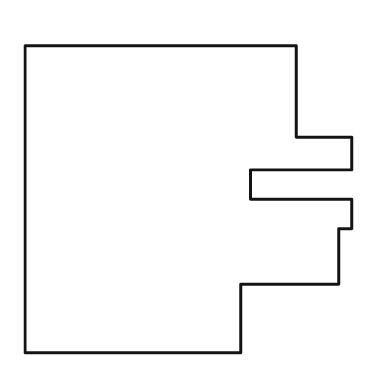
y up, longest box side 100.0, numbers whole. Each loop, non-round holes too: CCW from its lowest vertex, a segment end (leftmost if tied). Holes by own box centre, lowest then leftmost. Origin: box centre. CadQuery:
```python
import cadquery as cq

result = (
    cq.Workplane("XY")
    .moveTo(-50.0, -47.0)
    .lineTo(16.0, -47.0)
    .lineTo(16.0, -26.0)
    .lineTo(46.0, -26.0)
    .lineTo(46.0, -9.0)
    .lineTo(50.0, -9.0)
    .lineTo(50.0, 0.0)
    .lineTo(19.0, 0.0)
    .lineTo(19.0, 9.0)
    .lineTo(50.0, 9.0)
    .lineTo(50.0, 19.0)
    .lineTo(33.0, 19.0)
    .lineTo(33.0, 47.0)
    .lineTo(-50.0, 47.0)
    .close()
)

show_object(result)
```